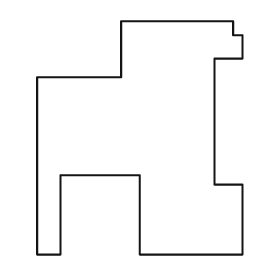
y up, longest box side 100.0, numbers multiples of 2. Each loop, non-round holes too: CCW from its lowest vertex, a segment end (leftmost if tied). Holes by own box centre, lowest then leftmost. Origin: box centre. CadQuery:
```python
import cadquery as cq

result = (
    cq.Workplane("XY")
    .moveTo(-44.0, -50.0)
    .lineTo(-34.0, -50.0)
    .lineTo(-34.0, -16.0)
    .lineTo(0.0, -16.0)
    .lineTo(0.0, -50.0)
    .lineTo(44.0, -50.0)
    .lineTo(44.0, -20.0)
    .lineTo(32.0, -20.0)
    .lineTo(32.0, 34.0)
    .lineTo(44.0, 34.0)
    .lineTo(44.0, 44.0)
    .lineTo(40.0, 44.0)
    .lineTo(40.0, 50.0)
    .lineTo(-8.0, 50.0)
    .lineTo(-8.0, 26.0)
    .lineTo(-44.0, 26.0)
    .close()
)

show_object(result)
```